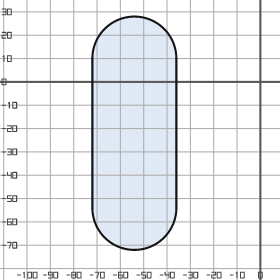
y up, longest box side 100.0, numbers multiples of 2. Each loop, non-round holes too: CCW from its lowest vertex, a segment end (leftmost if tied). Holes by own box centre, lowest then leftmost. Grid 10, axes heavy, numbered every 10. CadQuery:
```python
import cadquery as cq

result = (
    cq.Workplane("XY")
    .moveTo(-72.0, -54.0)
    .threePointArc((-54.0, -72.0), (-36.0, -54.0))
    .lineTo(-36.0, 10.0)
    .threePointArc((-54.0, 28.0), (-72.0, 10.0))
    .close()
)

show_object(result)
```